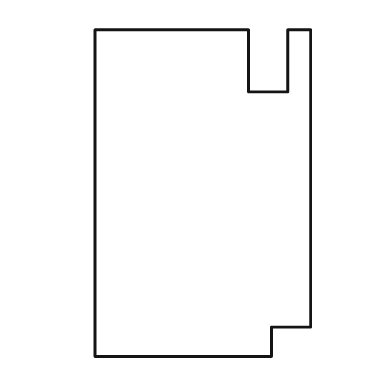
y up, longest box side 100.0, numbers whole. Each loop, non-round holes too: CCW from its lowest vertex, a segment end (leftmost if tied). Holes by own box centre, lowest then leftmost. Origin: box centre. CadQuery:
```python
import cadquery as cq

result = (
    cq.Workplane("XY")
    .moveTo(-33.0, -50.0)
    .lineTo(21.0, -50.0)
    .lineTo(21.0, -41.0)
    .lineTo(33.0, -41.0)
    .lineTo(33.0, 50.0)
    .lineTo(26.0, 50.0)
    .lineTo(26.0, 31.0)
    .lineTo(14.0, 31.0)
    .lineTo(14.0, 50.0)
    .lineTo(-33.0, 50.0)
    .close()
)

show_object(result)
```